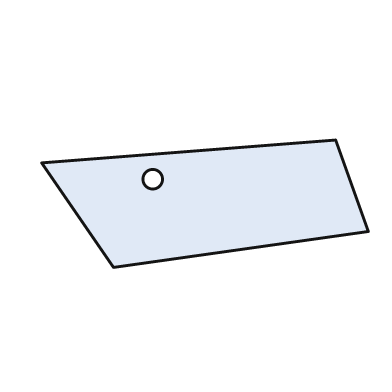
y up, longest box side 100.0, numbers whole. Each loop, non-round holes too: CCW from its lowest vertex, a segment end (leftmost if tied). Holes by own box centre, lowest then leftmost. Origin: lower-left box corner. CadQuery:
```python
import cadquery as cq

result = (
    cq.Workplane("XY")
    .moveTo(22.0, 0.0)
    .lineTo(100.0, 11.0)
    .lineTo(90.0, 39.0)
    .lineTo(0.0, 32.0)
    .close()
    .moveTo(34.0, 27.0)
    .circle(3.0)
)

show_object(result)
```